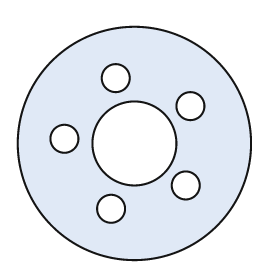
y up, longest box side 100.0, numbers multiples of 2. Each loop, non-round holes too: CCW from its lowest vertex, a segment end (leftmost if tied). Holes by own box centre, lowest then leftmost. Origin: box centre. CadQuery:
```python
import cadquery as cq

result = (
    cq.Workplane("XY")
    .moveTo(0.0, 0.0)
    .circle(50.0)
    .moveTo(-10.0, -28.0)
    .circle(6.0)
    .moveTo(22.0, -18.0)
    .circle(6.0)
    .moveTo(0.0, 0.0)
    .circle(18.0)
    .moveTo(-30.0, 2.0)
    .circle(6.0)
    .moveTo(24.0, 16.0)
    .circle(6.0)
    .moveTo(-8.0, 28.0)
    .circle(6.0)
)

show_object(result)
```